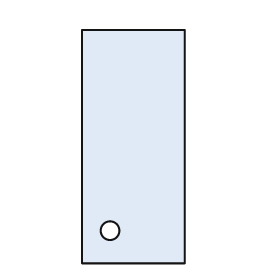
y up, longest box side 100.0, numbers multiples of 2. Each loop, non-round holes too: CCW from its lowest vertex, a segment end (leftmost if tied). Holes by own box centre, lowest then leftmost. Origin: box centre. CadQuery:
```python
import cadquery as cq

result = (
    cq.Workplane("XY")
    .moveTo(-22.0, -50.0)
    .lineTo(22.0, -50.0)
    .lineTo(22.0, 50.0)
    .lineTo(-22.0, 50.0)
    .close()
    .moveTo(-10.0, -36.0)
    .circle(4.0)
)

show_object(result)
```